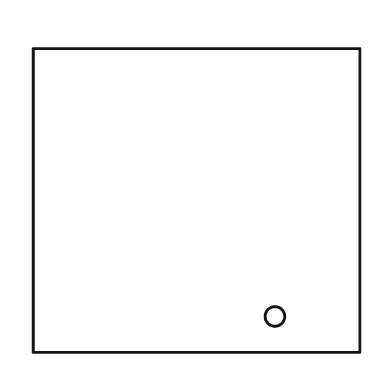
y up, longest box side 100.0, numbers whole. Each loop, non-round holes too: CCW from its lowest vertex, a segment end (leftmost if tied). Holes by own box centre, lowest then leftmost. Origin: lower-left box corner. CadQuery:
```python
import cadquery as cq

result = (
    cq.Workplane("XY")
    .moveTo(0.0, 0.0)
    .lineTo(100.0, 0.0)
    .lineTo(100.0, 93.0)
    .lineTo(0.0, 93.0)
    .close()
    .moveTo(74.0, 11.0)
    .circle(3.0)
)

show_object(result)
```